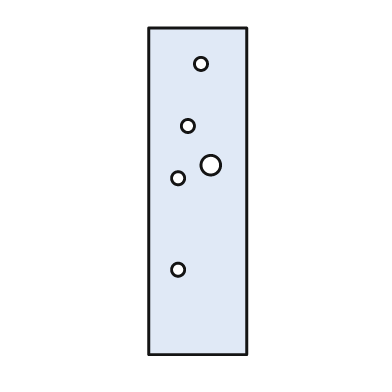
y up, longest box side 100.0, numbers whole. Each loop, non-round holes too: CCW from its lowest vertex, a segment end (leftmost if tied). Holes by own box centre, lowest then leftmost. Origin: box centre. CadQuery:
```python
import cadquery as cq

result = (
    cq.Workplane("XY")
    .moveTo(-15.0, -50.0)
    .lineTo(15.0, -50.0)
    .lineTo(15.0, 50.0)
    .lineTo(-15.0, 50.0)
    .close()
    .moveTo(-6.0, -24.0)
    .circle(2.0)
    .moveTo(-6.0, 4.0)
    .circle(2.0)
    .moveTo(4.0, 8.0)
    .circle(3.0)
    .moveTo(-3.0, 20.0)
    .circle(2.0)
    .moveTo(1.0, 39.0)
    .circle(2.0)
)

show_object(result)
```